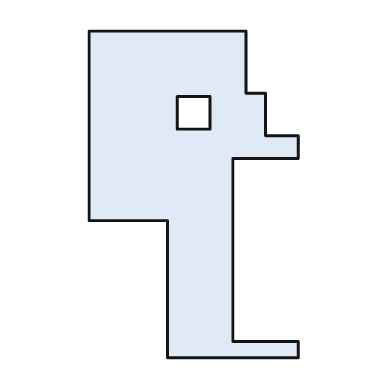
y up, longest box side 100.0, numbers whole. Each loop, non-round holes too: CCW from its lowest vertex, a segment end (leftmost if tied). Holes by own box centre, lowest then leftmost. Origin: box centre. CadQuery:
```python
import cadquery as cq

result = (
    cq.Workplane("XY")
    .moveTo(-8.0, -50.0)
    .lineTo(32.0, -50.0)
    .lineTo(32.0, -45.0)
    .lineTo(12.0, -45.0)
    .lineTo(12.0, 11.0)
    .lineTo(32.0, 11.0)
    .lineTo(32.0, 18.0)
    .lineTo(22.0, 18.0)
    .lineTo(22.0, 31.0)
    .lineTo(16.0, 31.0)
    .lineTo(16.0, 50.0)
    .lineTo(-32.0, 50.0)
    .lineTo(-32.0, -8.0)
    .lineTo(-8.0, -8.0)
    .close()
    .moveTo(-5.0, 20.0)
    .lineTo(5.0, 20.0)
    .lineTo(5.0, 30.0)
    .lineTo(-5.0, 30.0)
    .close()
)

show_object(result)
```